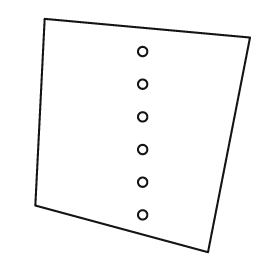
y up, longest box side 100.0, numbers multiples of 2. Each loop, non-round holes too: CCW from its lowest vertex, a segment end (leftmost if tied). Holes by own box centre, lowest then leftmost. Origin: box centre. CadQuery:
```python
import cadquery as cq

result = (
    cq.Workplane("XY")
    .moveTo(28.0, -50.0)
    .lineTo(46.0, 42.0)
    .lineTo(-42.0, 50.0)
    .lineTo(-46.0, -30.0)
    .close()
    .moveTo(0.0, -34.0)
    .circle(2.0)
    .moveTo(0.0, -20.0)
    .circle(2.0)
    .moveTo(0.0, -6.0)
    .circle(2.0)
    .moveTo(0.0, 8.0)
    .circle(2.0)
    .moveTo(0.0, 22.0)
    .circle(2.0)
    .moveTo(0.0, 36.0)
    .circle(2.0)
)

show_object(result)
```